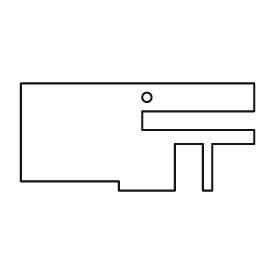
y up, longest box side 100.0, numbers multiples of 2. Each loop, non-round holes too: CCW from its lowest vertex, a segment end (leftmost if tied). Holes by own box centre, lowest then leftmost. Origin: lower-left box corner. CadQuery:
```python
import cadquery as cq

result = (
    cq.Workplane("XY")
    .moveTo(42.0, 0.0)
    .lineTo(66.0, 0.0)
    .lineTo(66.0, 20.0)
    .lineTo(78.0, 20.0)
    .lineTo(78.0, 0.0)
    .lineTo(82.0, 0.0)
    .lineTo(82.0, 20.0)
    .lineTo(100.0, 20.0)
    .lineTo(100.0, 26.0)
    .lineTo(52.0, 26.0)
    .lineTo(52.0, 34.0)
    .lineTo(100.0, 34.0)
    .lineTo(100.0, 46.0)
    .lineTo(0.0, 46.0)
    .lineTo(0.0, 4.0)
    .lineTo(42.0, 4.0)
    .close()
    .moveTo(54.0, 40.0)
    .circle(2.0)
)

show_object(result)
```